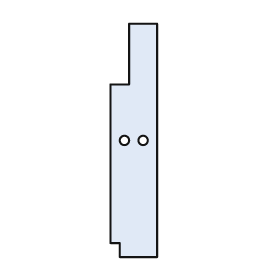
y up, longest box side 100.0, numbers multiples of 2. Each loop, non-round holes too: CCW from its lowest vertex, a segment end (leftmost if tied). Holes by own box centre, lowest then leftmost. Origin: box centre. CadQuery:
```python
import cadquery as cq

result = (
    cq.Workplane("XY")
    .moveTo(-6.0, -50.0)
    .lineTo(10.0, -50.0)
    .lineTo(10.0, 50.0)
    .lineTo(-2.0, 50.0)
    .lineTo(-2.0, 24.0)
    .lineTo(-10.0, 24.0)
    .lineTo(-10.0, -44.0)
    .lineTo(-6.0, -44.0)
    .close()
    .moveTo(-4.0, 0.0)
    .circle(2.0)
    .moveTo(4.0, 0.0)
    .circle(2.0)
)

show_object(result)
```